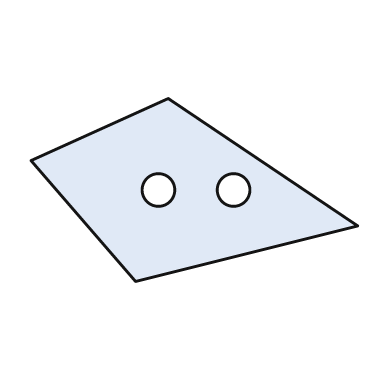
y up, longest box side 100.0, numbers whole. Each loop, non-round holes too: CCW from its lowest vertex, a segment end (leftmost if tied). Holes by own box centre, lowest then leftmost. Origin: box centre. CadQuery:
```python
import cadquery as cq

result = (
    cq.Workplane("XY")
    .moveTo(-18.0, -28.0)
    .lineTo(50.0, -11.0)
    .lineTo(-8.0, 28.0)
    .lineTo(-50.0, 9.0)
    .close()
    .moveTo(-11.0, 0.0)
    .circle(5.0)
    .moveTo(12.0, 0.0)
    .circle(5.0)
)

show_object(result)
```